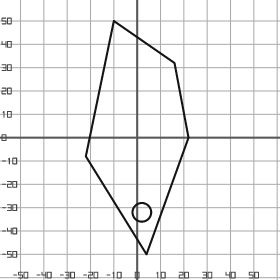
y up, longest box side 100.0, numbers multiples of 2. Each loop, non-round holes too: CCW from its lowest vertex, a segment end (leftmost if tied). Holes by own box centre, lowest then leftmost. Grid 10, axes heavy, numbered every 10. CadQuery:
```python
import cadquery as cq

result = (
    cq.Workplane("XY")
    .moveTo(4.0, -50.0)
    .lineTo(22.0, 0.0)
    .lineTo(16.0, 32.0)
    .lineTo(-10.0, 50.0)
    .lineTo(-22.0, -8.0)
    .close()
    .moveTo(2.0, -32.0)
    .circle(4.0)
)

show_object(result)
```